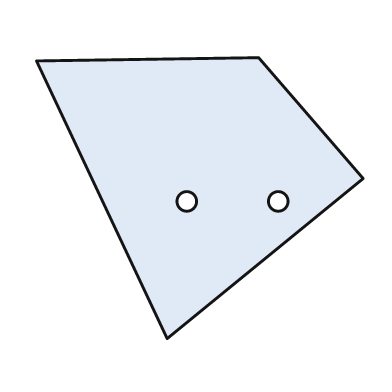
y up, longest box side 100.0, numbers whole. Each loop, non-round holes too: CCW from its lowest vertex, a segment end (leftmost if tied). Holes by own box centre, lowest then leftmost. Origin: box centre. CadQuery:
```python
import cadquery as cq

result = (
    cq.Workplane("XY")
    .moveTo(-10.0, -43.0)
    .lineTo(50.0, 6.0)
    .lineTo(18.0, 43.0)
    .lineTo(-50.0, 42.0)
    .close()
    .moveTo(-4.0, -1.0)
    .circle(3.0)
    .moveTo(24.0, -1.0)
    .circle(3.0)
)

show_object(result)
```